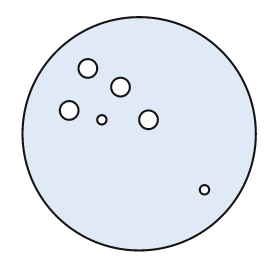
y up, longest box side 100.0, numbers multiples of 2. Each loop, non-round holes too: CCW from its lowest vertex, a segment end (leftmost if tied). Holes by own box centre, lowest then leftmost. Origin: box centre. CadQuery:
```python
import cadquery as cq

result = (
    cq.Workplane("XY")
    .moveTo(0.0, 0.0)
    .circle(50.0)
    .moveTo(28.0, -24.0)
    .circle(2.0)
    .moveTo(-16.0, 6.0)
    .circle(2.0)
    .moveTo(4.0, 6.0)
    .circle(4.0)
    .moveTo(-30.0, 10.0)
    .circle(4.0)
    .moveTo(-8.0, 20.0)
    .circle(4.0)
    .moveTo(-22.0, 28.0)
    .circle(4.0)
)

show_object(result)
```